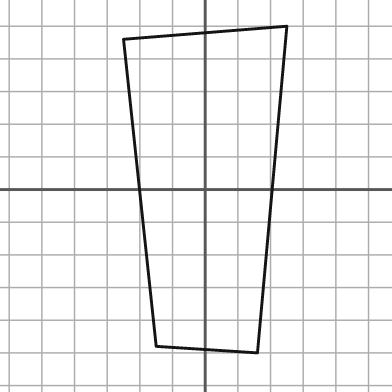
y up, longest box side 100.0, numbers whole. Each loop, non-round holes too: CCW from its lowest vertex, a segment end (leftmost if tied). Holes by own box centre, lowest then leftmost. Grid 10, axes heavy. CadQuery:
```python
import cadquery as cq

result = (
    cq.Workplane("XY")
    .moveTo(16.0, -50.0)
    .lineTo(25.0, 50.0)
    .lineTo(-25.0, 46.0)
    .lineTo(-15.0, -48.0)
    .close()
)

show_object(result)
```